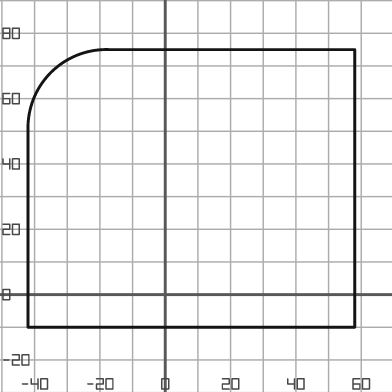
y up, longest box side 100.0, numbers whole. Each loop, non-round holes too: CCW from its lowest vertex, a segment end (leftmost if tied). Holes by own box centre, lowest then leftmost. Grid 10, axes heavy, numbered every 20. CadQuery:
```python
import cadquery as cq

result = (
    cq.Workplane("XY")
    .moveTo(-42.0, -10.0)
    .lineTo(58.0, -10.0)
    .lineTo(58.0, 75.0)
    .lineTo(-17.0, 75.0)
    .threePointArc((-35.0, 68.0), (-42.0, 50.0))
    .close()
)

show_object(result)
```